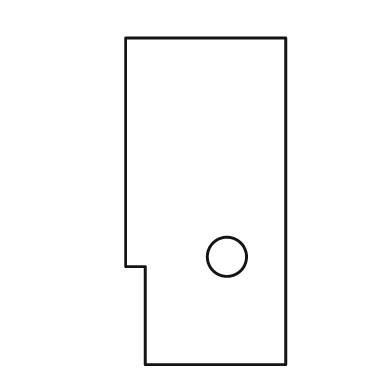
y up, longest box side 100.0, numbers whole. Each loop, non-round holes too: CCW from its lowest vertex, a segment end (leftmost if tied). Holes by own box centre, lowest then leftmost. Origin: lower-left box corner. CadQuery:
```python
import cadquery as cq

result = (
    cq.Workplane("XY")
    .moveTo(6.0, 0.0)
    .lineTo(49.0, 0.0)
    .lineTo(49.0, 100.0)
    .lineTo(0.0, 100.0)
    .lineTo(0.0, 30.0)
    .lineTo(6.0, 30.0)
    .close()
    .moveTo(31.0, 33.0)
    .circle(6.0)
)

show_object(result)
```